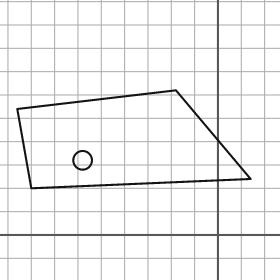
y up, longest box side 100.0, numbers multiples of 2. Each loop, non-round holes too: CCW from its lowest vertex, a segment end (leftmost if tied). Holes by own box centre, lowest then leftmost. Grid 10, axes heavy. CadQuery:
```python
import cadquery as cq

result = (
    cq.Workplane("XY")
    .moveTo(-80.0, 20.0)
    .lineTo(14.0, 24.0)
    .lineTo(-18.0, 62.0)
    .lineTo(-86.0, 54.0)
    .close()
    .moveTo(-58.0, 32.0)
    .circle(4.0)
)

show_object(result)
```